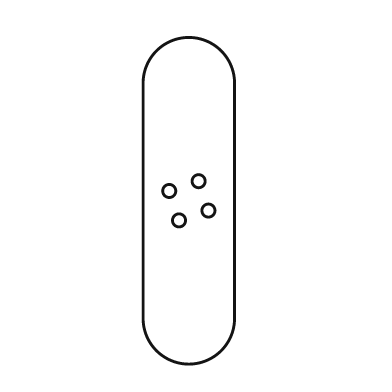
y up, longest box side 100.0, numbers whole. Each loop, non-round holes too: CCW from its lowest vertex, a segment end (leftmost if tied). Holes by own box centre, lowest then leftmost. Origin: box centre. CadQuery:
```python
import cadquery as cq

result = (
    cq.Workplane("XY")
    .moveTo(-14.0, -36.0)
    .threePointArc((0.0, -50.0), (14.0, -36.0))
    .lineTo(14.0, 36.0)
    .threePointArc((0.0, 50.0), (-14.0, 36.0))
    .close()
    .moveTo(-3.0, -6.0)
    .circle(2.0)
    .moveTo(6.0, -3.0)
    .circle(2.0)
    .moveTo(-6.0, 3.0)
    .circle(2.0)
    .moveTo(3.0, 6.0)
    .circle(2.0)
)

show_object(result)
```